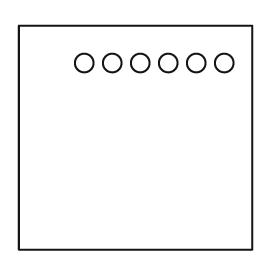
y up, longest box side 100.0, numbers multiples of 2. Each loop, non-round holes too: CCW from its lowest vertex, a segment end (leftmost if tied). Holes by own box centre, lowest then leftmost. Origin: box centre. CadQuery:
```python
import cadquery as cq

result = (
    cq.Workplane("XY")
    .moveTo(-50.0, -48.0)
    .lineTo(50.0, -48.0)
    .lineTo(50.0, 48.0)
    .lineTo(-50.0, 48.0)
    .close()
    .moveTo(-22.0, 32.0)
    .circle(4.0)
    .moveTo(-10.0, 32.0)
    .circle(4.0)
    .moveTo(2.0, 32.0)
    .circle(4.0)
    .moveTo(14.0, 32.0)
    .circle(4.0)
    .moveTo(26.0, 32.0)
    .circle(4.0)
    .moveTo(38.0, 32.0)
    .circle(4.0)
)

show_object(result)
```